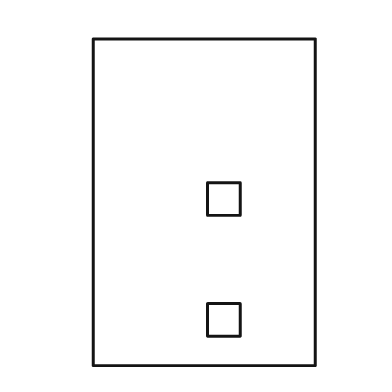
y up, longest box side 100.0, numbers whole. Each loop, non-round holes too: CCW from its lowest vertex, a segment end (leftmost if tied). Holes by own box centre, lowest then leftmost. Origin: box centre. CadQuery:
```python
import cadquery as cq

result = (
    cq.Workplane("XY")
    .moveTo(-34.0, -50.0)
    .lineTo(34.0, -50.0)
    .lineTo(34.0, 50.0)
    .lineTo(-34.0, 50.0)
    .close()
    .moveTo(1.0, -41.0)
    .lineTo(11.0, -41.0)
    .lineTo(11.0, -31.0)
    .lineTo(1.0, -31.0)
    .close()
    .moveTo(1.0, -4.0)
    .lineTo(11.0, -4.0)
    .lineTo(11.0, 6.0)
    .lineTo(1.0, 6.0)
    .close()
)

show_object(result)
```